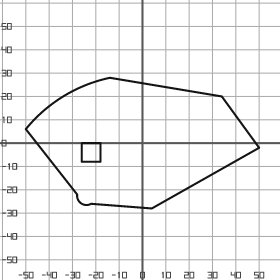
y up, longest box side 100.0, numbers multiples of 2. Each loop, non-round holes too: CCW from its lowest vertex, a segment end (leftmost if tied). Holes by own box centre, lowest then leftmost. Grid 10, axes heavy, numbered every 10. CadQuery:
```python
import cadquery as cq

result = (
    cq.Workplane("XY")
    .moveTo(4.0, -28.0)
    .lineTo(50.0, -2.0)
    .lineTo(34.0, 20.0)
    .lineTo(-14.0, 28.0)
    .threePointArc((-34.0, 20.0), (-50.0, 6.0))
    .lineTo(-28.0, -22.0)
    .threePointArc((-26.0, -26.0), (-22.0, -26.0))
    .close()
    .moveTo(-26.0, -8.0)
    .lineTo(-18.0, -8.0)
    .lineTo(-18.0, 0.0)
    .lineTo(-26.0, 0.0)
    .close()
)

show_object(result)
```